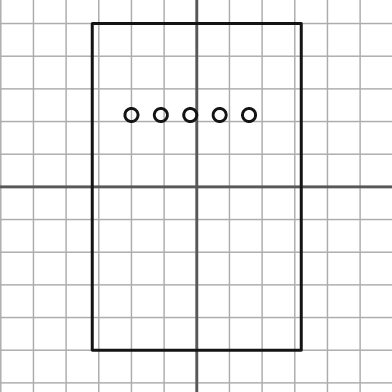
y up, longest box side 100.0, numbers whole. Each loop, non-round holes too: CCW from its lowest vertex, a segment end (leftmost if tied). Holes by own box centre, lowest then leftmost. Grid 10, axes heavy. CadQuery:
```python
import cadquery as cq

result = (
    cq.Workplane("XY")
    .moveTo(-32.0, -50.0)
    .lineTo(32.0, -50.0)
    .lineTo(32.0, 50.0)
    .lineTo(-32.0, 50.0)
    .close()
    .moveTo(-20.0, 22.0)
    .circle(2.0)
    .moveTo(-11.0, 22.0)
    .circle(2.0)
    .moveTo(-2.0, 22.0)
    .circle(2.0)
    .moveTo(7.0, 22.0)
    .circle(2.0)
    .moveTo(16.0, 22.0)
    .circle(2.0)
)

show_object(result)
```